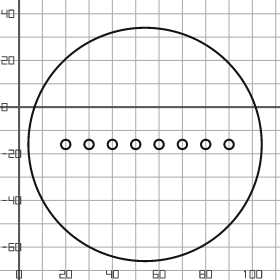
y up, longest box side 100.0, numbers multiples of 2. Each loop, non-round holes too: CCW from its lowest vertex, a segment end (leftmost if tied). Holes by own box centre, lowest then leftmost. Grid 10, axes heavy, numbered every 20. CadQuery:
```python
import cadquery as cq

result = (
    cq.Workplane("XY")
    .moveTo(54.0, -16.0)
    .circle(50.0)
    .moveTo(20.0, -16.0)
    .circle(2.0)
    .moveTo(30.0, -16.0)
    .circle(2.0)
    .moveTo(40.0, -16.0)
    .circle(2.0)
    .moveTo(50.0, -16.0)
    .circle(2.0)
    .moveTo(60.0, -16.0)
    .circle(2.0)
    .moveTo(70.0, -16.0)
    .circle(2.0)
    .moveTo(80.0, -16.0)
    .circle(2.0)
    .moveTo(90.0, -16.0)
    .circle(2.0)
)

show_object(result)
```